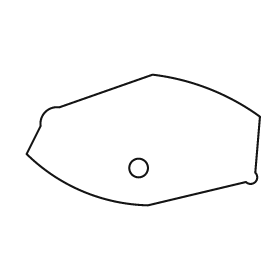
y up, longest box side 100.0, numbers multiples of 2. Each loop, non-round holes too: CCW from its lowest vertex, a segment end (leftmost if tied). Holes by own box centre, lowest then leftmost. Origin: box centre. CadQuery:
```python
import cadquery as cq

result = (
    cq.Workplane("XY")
    .moveTo(2.0, -28.0)
    .lineTo(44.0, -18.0)
    .threePointArc((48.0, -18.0), (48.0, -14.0))
    .lineTo(50.0, 10.0)
    .threePointArc((28.0, 22.0), (4.0, 28.0))
    .lineTo(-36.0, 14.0)
    .threePointArc((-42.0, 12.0), (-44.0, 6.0))
    .lineTo(-50.0, -6.0)
    .threePointArc((-26.0, -22.0), (2.0, -28.0))
    .close()
    .moveTo(-2.0, -12.0)
    .circle(4.0)
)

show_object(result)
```